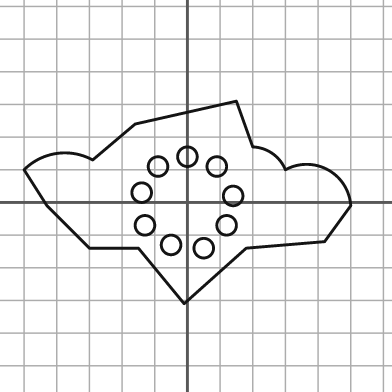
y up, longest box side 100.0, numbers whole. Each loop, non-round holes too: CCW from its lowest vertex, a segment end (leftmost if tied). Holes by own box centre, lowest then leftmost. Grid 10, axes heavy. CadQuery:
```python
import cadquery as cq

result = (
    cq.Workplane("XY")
    .moveTo(-1.0, -31.0)
    .lineTo(18.0, -14.0)
    .lineTo(42.0, -12.0)
    .lineTo(50.0, -1.0)
    .threePointArc((43.0, 10.0), (30.0, 10.0))
    .threePointArc((26.0, 15.0), (20.0, 17.0))
    .lineTo(15.0, 31.0)
    .lineTo(-16.0, 24.0)
    .lineTo(-29.0, 13.0)
    .threePointArc((-40.0, 15.0), (-50.0, 10.0))
    .lineTo(-43.0, -1.0)
    .lineTo(-30.0, -14.0)
    .lineTo(-15.0, -14.0)
    .close()
    .moveTo(5.0, -14.0)
    .circle(3.0)
    .moveTo(-5.0, -13.0)
    .circle(3.0)
    .moveTo(-13.0, -7.0)
    .circle(3.0)
    .moveTo(12.0, -7.0)
    .circle(3.0)
    .moveTo(14.0, 2.0)
    .circle(3.0)
    .moveTo(-14.0, 3.0)
    .circle(3.0)
    .moveTo(-9.0, 11.0)
    .circle(3.0)
    .moveTo(9.0, 11.0)
    .circle(3.0)
    .moveTo(0.0, 14.0)
    .circle(3.0)
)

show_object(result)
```